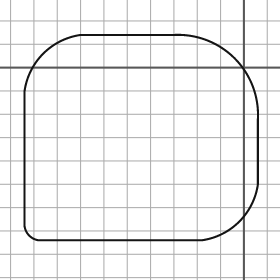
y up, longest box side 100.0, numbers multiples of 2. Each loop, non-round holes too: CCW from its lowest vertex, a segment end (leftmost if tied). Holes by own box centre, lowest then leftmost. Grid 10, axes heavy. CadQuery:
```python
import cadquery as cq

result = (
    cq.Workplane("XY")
    .moveTo(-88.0, -74.0)
    .lineTo(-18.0, -74.0)
    .threePointArc((-2.0, -66.0), (6.0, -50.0))
    .lineTo(6.0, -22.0)
    .threePointArc((-4.0, 4.0), (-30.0, 14.0))
    .lineTo(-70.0, 14.0)
    .threePointArc((-86.0, 6.0), (-94.0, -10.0))
    .lineTo(-94.0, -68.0)
    .threePointArc((-92.0, -72.0), (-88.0, -74.0))
    .close()
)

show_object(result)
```